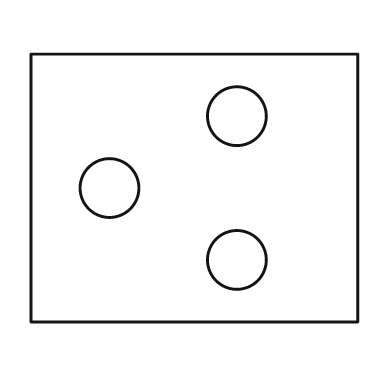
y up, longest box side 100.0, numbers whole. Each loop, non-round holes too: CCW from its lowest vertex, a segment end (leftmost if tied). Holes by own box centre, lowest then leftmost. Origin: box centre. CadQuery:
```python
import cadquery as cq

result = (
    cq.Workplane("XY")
    .moveTo(-50.0, -41.0)
    .lineTo(50.0, -41.0)
    .lineTo(50.0, 41.0)
    .lineTo(-50.0, 41.0)
    .close()
    .moveTo(13.0, -22.0)
    .circle(9.0)
    .moveTo(-26.0, 0.0)
    .circle(9.0)
    .moveTo(13.0, 22.0)
    .circle(9.0)
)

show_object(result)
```